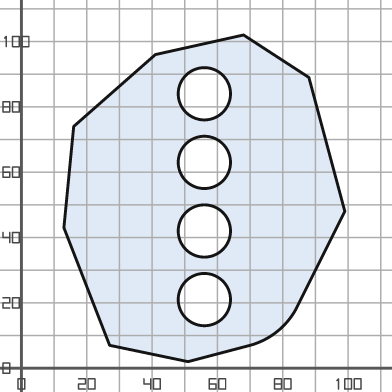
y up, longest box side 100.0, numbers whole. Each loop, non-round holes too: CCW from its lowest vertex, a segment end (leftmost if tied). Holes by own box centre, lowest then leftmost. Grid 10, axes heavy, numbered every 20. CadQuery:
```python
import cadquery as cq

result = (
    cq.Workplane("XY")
    .moveTo(51.0, 2.0)
    .lineTo(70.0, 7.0)
    .threePointArc((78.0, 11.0), (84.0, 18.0))
    .lineTo(99.0, 48.0)
    .lineTo(88.0, 89.0)
    .lineTo(68.0, 102.0)
    .lineTo(41.0, 96.0)
    .lineTo(16.0, 74.0)
    .lineTo(13.0, 43.0)
    .lineTo(27.0, 7.0)
    .close()
    .moveTo(56.0, 21.0)
    .circle(8.0)
    .moveTo(56.0, 42.0)
    .circle(8.0)
    .moveTo(56.0, 63.0)
    .circle(8.0)
    .moveTo(56.0, 84.0)
    .circle(8.0)
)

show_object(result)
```